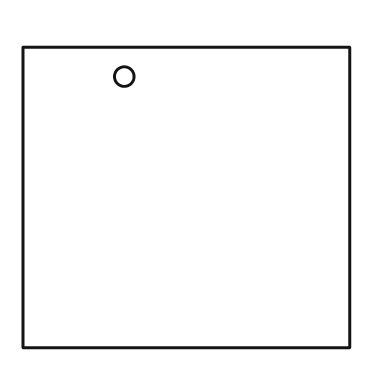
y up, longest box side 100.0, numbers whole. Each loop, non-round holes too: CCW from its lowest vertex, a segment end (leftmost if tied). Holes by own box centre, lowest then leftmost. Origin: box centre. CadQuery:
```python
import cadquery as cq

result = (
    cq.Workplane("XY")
    .moveTo(-50.0, -46.0)
    .lineTo(50.0, -46.0)
    .lineTo(50.0, 46.0)
    .lineTo(-50.0, 46.0)
    .close()
    .moveTo(-19.0, 37.0)
    .circle(3.0)
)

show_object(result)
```